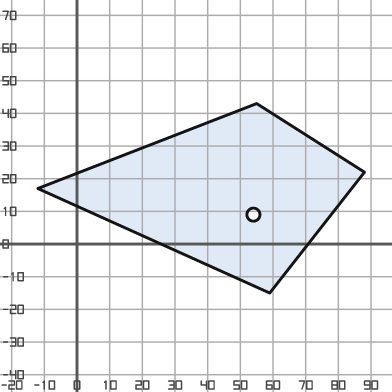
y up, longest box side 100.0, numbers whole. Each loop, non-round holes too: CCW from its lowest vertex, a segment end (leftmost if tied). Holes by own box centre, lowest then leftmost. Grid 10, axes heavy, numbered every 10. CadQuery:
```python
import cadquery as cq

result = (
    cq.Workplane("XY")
    .moveTo(59.0, -15.0)
    .lineTo(88.0, 22.0)
    .lineTo(55.0, 43.0)
    .lineTo(-12.0, 17.0)
    .close()
    .moveTo(54.0, 9.0)
    .circle(2.0)
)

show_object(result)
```